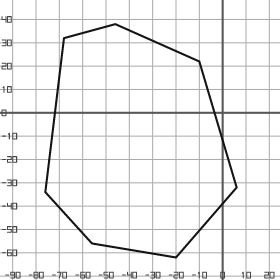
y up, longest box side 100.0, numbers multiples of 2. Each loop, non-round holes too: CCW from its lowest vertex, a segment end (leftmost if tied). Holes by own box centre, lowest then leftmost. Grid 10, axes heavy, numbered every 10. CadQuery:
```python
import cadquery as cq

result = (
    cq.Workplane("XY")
    .moveTo(-20.0, -62.0)
    .lineTo(6.0, -32.0)
    .lineTo(-10.0, 22.0)
    .lineTo(-46.0, 38.0)
    .lineTo(-68.0, 32.0)
    .lineTo(-76.0, -34.0)
    .lineTo(-56.0, -56.0)
    .close()
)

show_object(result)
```